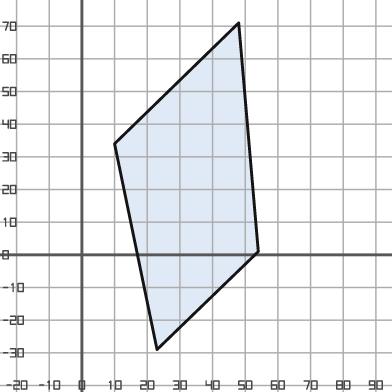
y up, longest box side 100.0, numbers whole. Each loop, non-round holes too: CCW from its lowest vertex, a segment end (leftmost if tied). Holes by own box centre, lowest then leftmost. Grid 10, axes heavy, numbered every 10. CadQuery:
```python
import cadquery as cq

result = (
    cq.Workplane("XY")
    .moveTo(23.0, -29.0)
    .lineTo(54.0, 1.0)
    .lineTo(48.0, 71.0)
    .lineTo(10.0, 34.0)
    .close()
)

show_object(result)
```